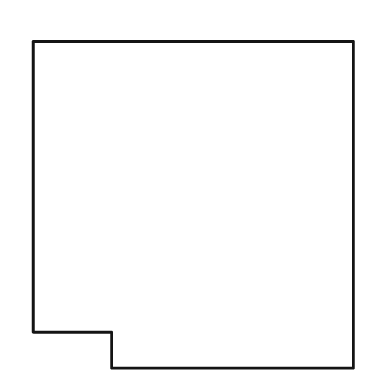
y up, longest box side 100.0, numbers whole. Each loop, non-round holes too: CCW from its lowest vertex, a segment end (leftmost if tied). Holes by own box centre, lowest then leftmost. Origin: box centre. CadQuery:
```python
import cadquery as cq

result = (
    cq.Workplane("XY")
    .moveTo(-25.0, -50.0)
    .lineTo(49.0, -50.0)
    .lineTo(49.0, 50.0)
    .lineTo(-49.0, 50.0)
    .lineTo(-49.0, -39.0)
    .lineTo(-25.0, -39.0)
    .close()
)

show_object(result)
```